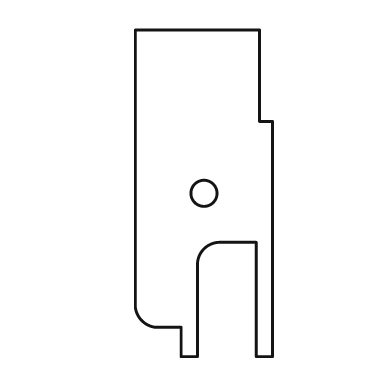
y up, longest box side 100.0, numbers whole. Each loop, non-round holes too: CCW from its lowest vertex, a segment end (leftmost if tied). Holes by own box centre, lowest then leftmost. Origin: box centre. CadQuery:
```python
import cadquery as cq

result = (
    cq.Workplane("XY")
    .moveTo(-7.0, -50.0)
    .lineTo(-2.0, -50.0)
    .lineTo(-2.0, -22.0)
    .threePointArc((0.0, -17.0), (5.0, -15.0))
    .lineTo(16.0, -15.0)
    .lineTo(16.0, -50.0)
    .lineTo(21.0, -50.0)
    .lineTo(21.0, 22.0)
    .lineTo(17.0, 22.0)
    .lineTo(17.0, 50.0)
    .lineTo(-21.0, 50.0)
    .lineTo(-21.0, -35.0)
    .threePointArc((-19.0, -39.0), (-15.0, -41.0))
    .lineTo(-7.0, -41.0)
    .close()
    .moveTo(0.0, 0.0)
    .circle(4.0)
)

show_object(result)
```